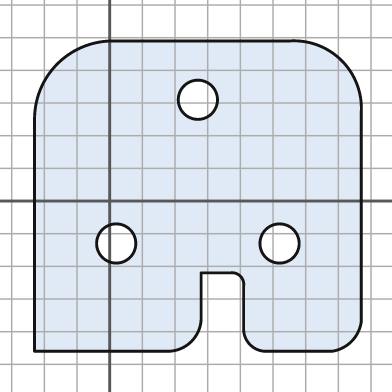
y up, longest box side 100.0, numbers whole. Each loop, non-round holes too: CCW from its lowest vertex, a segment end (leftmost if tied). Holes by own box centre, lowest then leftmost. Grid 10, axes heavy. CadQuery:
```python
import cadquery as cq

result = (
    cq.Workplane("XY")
    .moveTo(-23.0, -46.0)
    .lineTo(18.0, -46.0)
    .threePointArc((25.0, -43.0), (28.0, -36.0))
    .lineTo(28.0, -22.0)
    .lineTo(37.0, -22.0)
    .threePointArc((40.0, -23.0), (41.0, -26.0))
    .lineTo(41.0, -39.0)
    .threePointArc((43.0, -44.0), (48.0, -46.0))
    .lineTo(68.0, -46.0)
    .threePointArc((74.0, -43.0), (77.0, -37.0))
    .lineTo(77.0, 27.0)
    .threePointArc((71.0, 43.0), (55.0, 49.0))
    .lineTo(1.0, 49.0)
    .threePointArc((-16.0, 42.0), (-23.0, 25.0))
    .close()
    .moveTo(2.0, -13.0)
    .circle(6.0)
    .moveTo(52.0, -13.0)
    .circle(6.0)
    .moveTo(27.0, 31.0)
    .circle(6.0)
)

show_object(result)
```